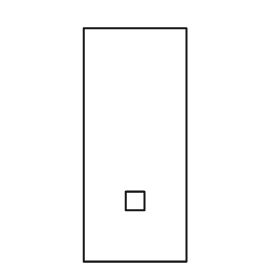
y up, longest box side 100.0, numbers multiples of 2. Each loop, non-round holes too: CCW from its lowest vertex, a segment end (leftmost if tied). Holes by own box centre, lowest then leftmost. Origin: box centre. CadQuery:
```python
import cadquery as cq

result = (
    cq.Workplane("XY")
    .moveTo(-22.0, -50.0)
    .lineTo(22.0, -50.0)
    .lineTo(22.0, 50.0)
    .lineTo(-22.0, 50.0)
    .close()
    .moveTo(-4.0, -28.0)
    .lineTo(4.0, -28.0)
    .lineTo(4.0, -20.0)
    .lineTo(-4.0, -20.0)
    .close()
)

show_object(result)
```